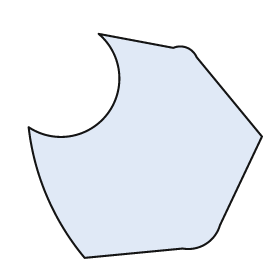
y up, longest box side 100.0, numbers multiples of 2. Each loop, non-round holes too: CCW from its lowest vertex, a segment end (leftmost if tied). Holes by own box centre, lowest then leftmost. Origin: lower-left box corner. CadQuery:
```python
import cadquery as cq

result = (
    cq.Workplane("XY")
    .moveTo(24.0, 0.0)
    .lineTo(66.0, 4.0)
    .threePointArc((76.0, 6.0), (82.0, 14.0))
    .lineTo(100.0, 52.0)
    .lineTo(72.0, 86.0)
    .threePointArc((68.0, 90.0), (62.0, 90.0))
    .lineTo(30.0, 96.0)
    .threePointArc((34.0, 62.0), (0.0, 56.0))
    .threePointArc((8.0, 26.0), (24.0, 0.0))
    .close()
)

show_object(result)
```